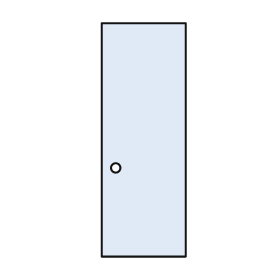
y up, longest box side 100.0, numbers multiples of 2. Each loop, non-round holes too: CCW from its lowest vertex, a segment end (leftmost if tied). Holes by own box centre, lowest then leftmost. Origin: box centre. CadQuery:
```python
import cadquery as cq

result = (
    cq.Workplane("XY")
    .moveTo(-18.0, -50.0)
    .lineTo(18.0, -50.0)
    .lineTo(18.0, 50.0)
    .lineTo(-18.0, 50.0)
    .close()
    .moveTo(-12.0, -12.0)
    .circle(2.0)
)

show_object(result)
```